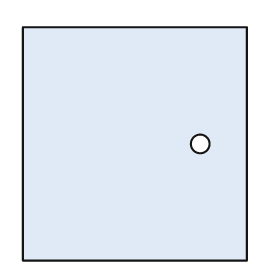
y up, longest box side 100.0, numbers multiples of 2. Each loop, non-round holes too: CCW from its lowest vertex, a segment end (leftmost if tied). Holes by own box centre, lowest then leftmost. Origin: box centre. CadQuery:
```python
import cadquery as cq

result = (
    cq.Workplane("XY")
    .moveTo(-48.0, -50.0)
    .lineTo(48.0, -50.0)
    .lineTo(48.0, 50.0)
    .lineTo(-48.0, 50.0)
    .close()
    .moveTo(28.0, 0.0)
    .circle(4.0)
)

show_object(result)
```